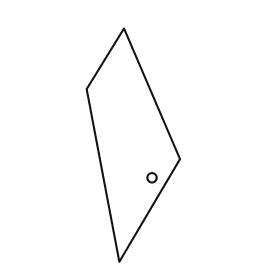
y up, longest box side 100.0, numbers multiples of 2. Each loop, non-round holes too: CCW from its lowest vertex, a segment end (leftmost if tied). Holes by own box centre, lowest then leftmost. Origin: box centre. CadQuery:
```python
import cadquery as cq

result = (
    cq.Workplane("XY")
    .moveTo(-6.0, -50.0)
    .lineTo(20.0, -6.0)
    .lineTo(-4.0, 50.0)
    .lineTo(-20.0, 24.0)
    .close()
    .moveTo(8.0, -14.0)
    .circle(2.0)
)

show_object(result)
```